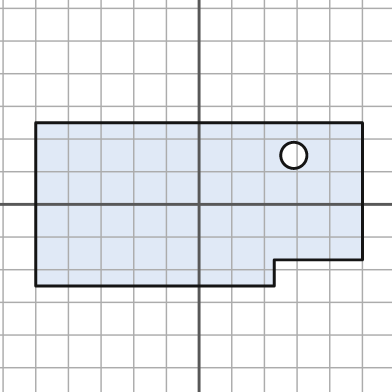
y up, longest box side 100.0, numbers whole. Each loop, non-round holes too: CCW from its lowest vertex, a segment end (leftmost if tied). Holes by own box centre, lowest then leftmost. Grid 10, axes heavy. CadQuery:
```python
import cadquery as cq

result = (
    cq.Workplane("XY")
    .moveTo(-50.0, -25.0)
    .lineTo(23.0, -25.0)
    .lineTo(23.0, -17.0)
    .lineTo(50.0, -17.0)
    .lineTo(50.0, 25.0)
    .lineTo(-50.0, 25.0)
    .close()
    .moveTo(29.0, 15.0)
    .circle(4.0)
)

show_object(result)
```